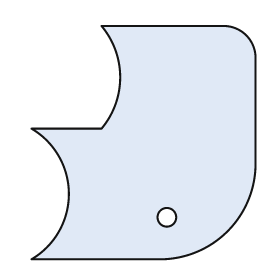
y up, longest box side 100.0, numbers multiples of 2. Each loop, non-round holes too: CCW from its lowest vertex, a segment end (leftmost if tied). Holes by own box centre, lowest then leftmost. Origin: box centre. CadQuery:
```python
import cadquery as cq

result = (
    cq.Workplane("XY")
    .moveTo(-48.0, -50.0)
    .lineTo(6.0, -50.0)
    .threePointArc((36.0, -38.0), (48.0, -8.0))
    .lineTo(48.0, 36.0)
    .threePointArc((44.0, 46.0), (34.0, 50.0))
    .lineTo(-18.0, 50.0)
    .threePointArc((-10.0, 28.0), (-18.0, 6.0))
    .lineTo(-48.0, 6.0)
    .threePointArc((-32.0, -22.0), (-48.0, -50.0))
    .close()
    .moveTo(10.0, -32.0)
    .circle(4.0)
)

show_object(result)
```